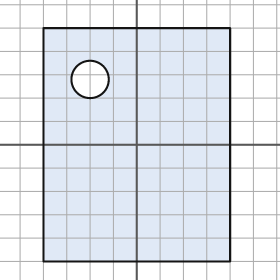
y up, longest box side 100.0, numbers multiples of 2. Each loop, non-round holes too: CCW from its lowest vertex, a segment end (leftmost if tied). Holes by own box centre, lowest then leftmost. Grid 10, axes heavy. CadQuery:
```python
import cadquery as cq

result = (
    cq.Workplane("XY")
    .moveTo(-40.0, -50.0)
    .lineTo(40.0, -50.0)
    .lineTo(40.0, 50.0)
    .lineTo(-40.0, 50.0)
    .close()
    .moveTo(-20.0, 28.0)
    .circle(8.0)
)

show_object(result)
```